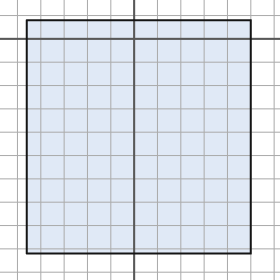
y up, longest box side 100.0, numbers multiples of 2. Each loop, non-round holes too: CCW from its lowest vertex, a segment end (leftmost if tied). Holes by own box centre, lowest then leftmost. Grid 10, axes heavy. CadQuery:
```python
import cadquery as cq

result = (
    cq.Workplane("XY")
    .moveTo(-46.0, -92.0)
    .lineTo(50.0, -92.0)
    .lineTo(50.0, 8.0)
    .lineTo(-46.0, 8.0)
    .close()
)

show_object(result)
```